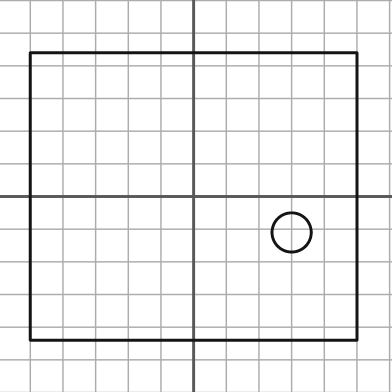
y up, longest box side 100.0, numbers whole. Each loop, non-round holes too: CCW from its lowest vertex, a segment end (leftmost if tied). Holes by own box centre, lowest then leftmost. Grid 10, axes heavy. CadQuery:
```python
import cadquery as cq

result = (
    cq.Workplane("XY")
    .moveTo(-50.0, -44.0)
    .lineTo(50.0, -44.0)
    .lineTo(50.0, 44.0)
    .lineTo(-50.0, 44.0)
    .close()
    .moveTo(30.0, -11.0)
    .circle(6.0)
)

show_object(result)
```